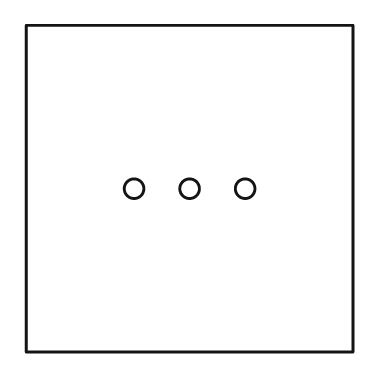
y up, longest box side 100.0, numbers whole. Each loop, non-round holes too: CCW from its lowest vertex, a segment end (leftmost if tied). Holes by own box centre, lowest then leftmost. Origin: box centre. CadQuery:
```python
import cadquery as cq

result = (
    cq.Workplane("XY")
    .moveTo(-50.0, -50.0)
    .lineTo(50.0, -50.0)
    .lineTo(50.0, 50.0)
    .lineTo(-50.0, 50.0)
    .close()
    .moveTo(-17.0, 0.0)
    .circle(3.0)
    .moveTo(0.0, 0.0)
    .circle(3.0)
    .moveTo(17.0, 0.0)
    .circle(3.0)
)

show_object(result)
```